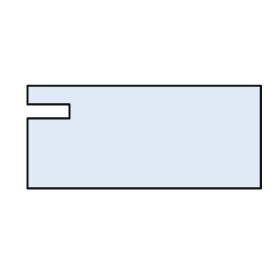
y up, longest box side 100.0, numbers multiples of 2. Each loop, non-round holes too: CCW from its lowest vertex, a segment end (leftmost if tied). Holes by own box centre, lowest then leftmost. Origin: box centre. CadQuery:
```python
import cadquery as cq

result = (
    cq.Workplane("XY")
    .moveTo(-50.0, -22.0)
    .lineTo(50.0, -22.0)
    .lineTo(50.0, 22.0)
    .lineTo(-50.0, 22.0)
    .lineTo(-50.0, 14.0)
    .lineTo(-32.0, 14.0)
    .lineTo(-32.0, 8.0)
    .lineTo(-50.0, 8.0)
    .close()
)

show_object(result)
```